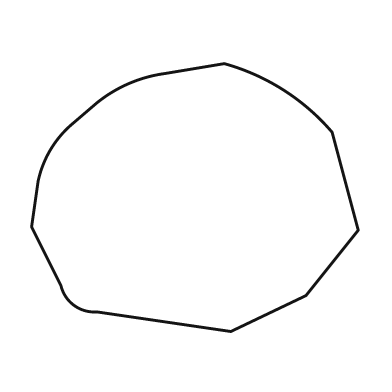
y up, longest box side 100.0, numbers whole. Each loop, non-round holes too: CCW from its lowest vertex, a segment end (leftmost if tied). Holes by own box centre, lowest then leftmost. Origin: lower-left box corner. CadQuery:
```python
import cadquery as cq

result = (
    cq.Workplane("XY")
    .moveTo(61.0, 0.0)
    .lineTo(84.0, 11.0)
    .lineTo(100.0, 31.0)
    .lineTo(92.0, 61.0)
    .threePointArc((77.0, 74.0), (59.0, 82.0))
    .lineTo(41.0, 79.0)
    .threePointArc((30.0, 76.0), (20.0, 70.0))
    .lineTo(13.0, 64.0)
    .threePointArc((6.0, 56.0), (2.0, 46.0))
    .lineTo(0.0, 32.0)
    .lineTo(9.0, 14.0)
    .threePointArc((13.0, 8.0), (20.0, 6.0))
    .close()
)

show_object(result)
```